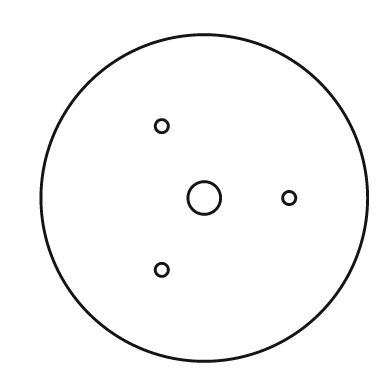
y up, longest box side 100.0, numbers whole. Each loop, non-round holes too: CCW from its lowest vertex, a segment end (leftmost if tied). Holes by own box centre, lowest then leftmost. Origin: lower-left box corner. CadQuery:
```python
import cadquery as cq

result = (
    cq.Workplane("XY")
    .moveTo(50.0, 50.0)
    .circle(50.0)
    .moveTo(37.0, 28.0)
    .circle(2.0)
    .moveTo(50.0, 50.0)
    .circle(5.0)
    .moveTo(76.0, 50.0)
    .circle(2.0)
    .moveTo(37.0, 72.0)
    .circle(2.0)
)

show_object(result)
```